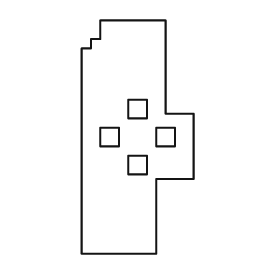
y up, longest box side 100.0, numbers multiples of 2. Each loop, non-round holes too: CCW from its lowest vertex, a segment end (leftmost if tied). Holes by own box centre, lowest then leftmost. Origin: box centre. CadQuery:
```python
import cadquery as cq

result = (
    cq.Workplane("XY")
    .moveTo(-24.0, -50.0)
    .lineTo(8.0, -50.0)
    .lineTo(8.0, -18.0)
    .lineTo(24.0, -18.0)
    .lineTo(24.0, 10.0)
    .lineTo(12.0, 10.0)
    .lineTo(12.0, 50.0)
    .lineTo(-16.0, 50.0)
    .lineTo(-16.0, 42.0)
    .lineTo(-20.0, 42.0)
    .lineTo(-20.0, 38.0)
    .lineTo(-24.0, 38.0)
    .close()
    .moveTo(-4.0, -16.0)
    .lineTo(4.0, -16.0)
    .lineTo(4.0, -8.0)
    .lineTo(-4.0, -8.0)
    .close()
    .moveTo(-16.0, -4.0)
    .lineTo(-8.0, -4.0)
    .lineTo(-8.0, 4.0)
    .lineTo(-16.0, 4.0)
    .close()
    .moveTo(8.0, -4.0)
    .lineTo(16.0, -4.0)
    .lineTo(16.0, 4.0)
    .lineTo(8.0, 4.0)
    .close()
    .moveTo(-4.0, 8.0)
    .lineTo(4.0, 8.0)
    .lineTo(4.0, 16.0)
    .lineTo(-4.0, 16.0)
    .close()
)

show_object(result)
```